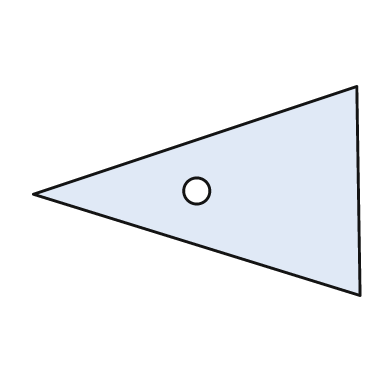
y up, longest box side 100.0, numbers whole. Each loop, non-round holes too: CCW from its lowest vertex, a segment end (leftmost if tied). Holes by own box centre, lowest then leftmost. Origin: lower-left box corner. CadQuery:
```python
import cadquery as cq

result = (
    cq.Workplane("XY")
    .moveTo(100.0, 0.0)
    .lineTo(99.0, 64.0)
    .lineTo(0.0, 31.0)
    .close()
    .moveTo(50.0, 32.0)
    .circle(4.0)
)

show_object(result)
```